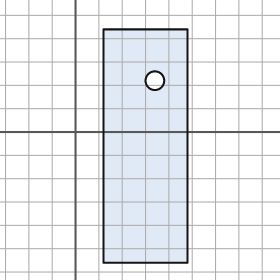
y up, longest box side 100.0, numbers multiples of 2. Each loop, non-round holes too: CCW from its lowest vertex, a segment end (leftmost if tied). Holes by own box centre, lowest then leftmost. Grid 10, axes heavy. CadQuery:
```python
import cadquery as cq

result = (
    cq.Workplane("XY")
    .moveTo(12.0, -56.0)
    .lineTo(48.0, -56.0)
    .lineTo(48.0, 44.0)
    .lineTo(12.0, 44.0)
    .close()
    .moveTo(34.0, 22.0)
    .circle(4.0)
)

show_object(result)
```